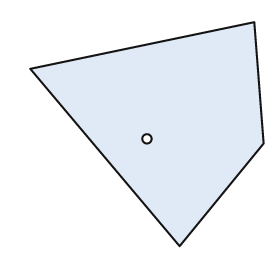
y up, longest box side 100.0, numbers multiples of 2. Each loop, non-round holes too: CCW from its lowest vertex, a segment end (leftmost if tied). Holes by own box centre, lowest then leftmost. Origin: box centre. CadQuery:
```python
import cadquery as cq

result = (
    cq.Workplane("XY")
    .moveTo(14.0, -48.0)
    .lineTo(50.0, -4.0)
    .lineTo(46.0, 48.0)
    .lineTo(-50.0, 28.0)
    .close()
    .moveTo(0.0, -2.0)
    .circle(2.0)
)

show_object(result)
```